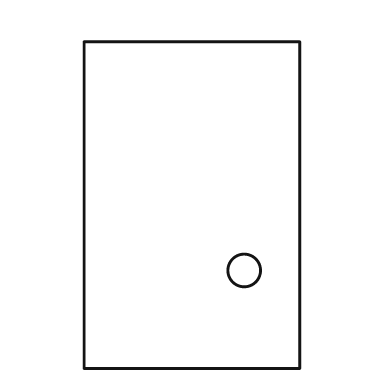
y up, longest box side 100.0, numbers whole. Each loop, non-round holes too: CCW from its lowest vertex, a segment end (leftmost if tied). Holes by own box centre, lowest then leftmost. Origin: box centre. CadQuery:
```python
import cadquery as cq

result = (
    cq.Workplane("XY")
    .moveTo(-33.0, -50.0)
    .lineTo(33.0, -50.0)
    .lineTo(33.0, 50.0)
    .lineTo(-33.0, 50.0)
    .close()
    .moveTo(16.0, -20.0)
    .circle(5.0)
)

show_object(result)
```